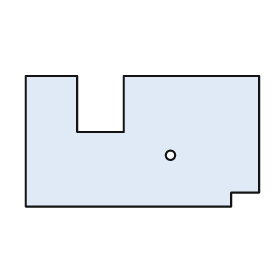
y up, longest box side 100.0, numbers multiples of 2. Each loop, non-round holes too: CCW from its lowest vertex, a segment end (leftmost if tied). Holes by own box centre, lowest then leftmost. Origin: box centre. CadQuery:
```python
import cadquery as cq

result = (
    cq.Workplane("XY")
    .moveTo(-50.0, -28.0)
    .lineTo(38.0, -28.0)
    .lineTo(38.0, -22.0)
    .lineTo(50.0, -22.0)
    .lineTo(50.0, 28.0)
    .lineTo(-8.0, 28.0)
    .lineTo(-8.0, 4.0)
    .lineTo(-28.0, 4.0)
    .lineTo(-28.0, 28.0)
    .lineTo(-50.0, 28.0)
    .close()
    .moveTo(12.0, -6.0)
    .circle(2.0)
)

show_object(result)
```